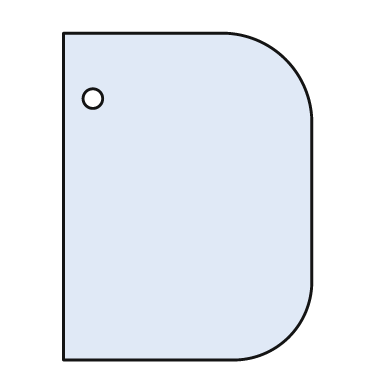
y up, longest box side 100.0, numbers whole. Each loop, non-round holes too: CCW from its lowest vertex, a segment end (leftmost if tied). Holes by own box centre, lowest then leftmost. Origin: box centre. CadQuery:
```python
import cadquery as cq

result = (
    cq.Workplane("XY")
    .moveTo(-38.0, -50.0)
    .lineTo(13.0, -50.0)
    .threePointArc((31.0, -43.0), (38.0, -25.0))
    .lineTo(38.0, 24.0)
    .threePointArc((30.0, 42.0), (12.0, 50.0))
    .lineTo(-38.0, 50.0)
    .close()
    .moveTo(-29.0, 30.0)
    .circle(3.0)
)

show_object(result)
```